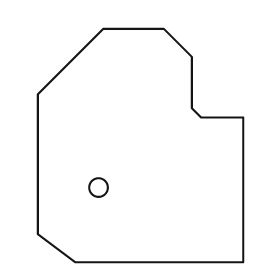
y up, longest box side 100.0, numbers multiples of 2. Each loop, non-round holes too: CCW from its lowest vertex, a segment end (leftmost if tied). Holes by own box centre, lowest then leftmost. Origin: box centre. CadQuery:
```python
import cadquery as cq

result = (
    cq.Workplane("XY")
    .moveTo(-28.0, -50.0)
    .lineTo(44.0, -50.0)
    .lineTo(44.0, 12.0)
    .lineTo(26.0, 12.0)
    .lineTo(22.0, 16.0)
    .lineTo(22.0, 38.0)
    .lineTo(10.0, 50.0)
    .lineTo(-16.0, 50.0)
    .lineTo(-44.0, 22.0)
    .lineTo(-44.0, -38.0)
    .close()
    .moveTo(-18.0, -18.0)
    .circle(4.0)
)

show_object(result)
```